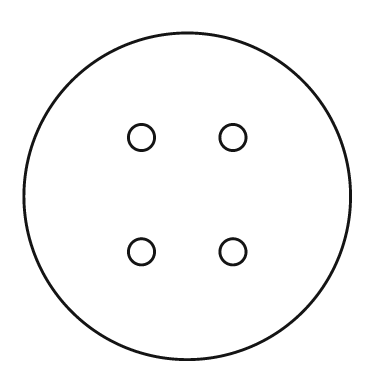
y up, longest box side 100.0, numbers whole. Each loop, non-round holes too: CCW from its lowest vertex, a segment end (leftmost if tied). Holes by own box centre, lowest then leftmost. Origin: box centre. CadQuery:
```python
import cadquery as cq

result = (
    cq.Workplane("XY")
    .moveTo(0.0, 0.0)
    .circle(50.0)
    .moveTo(-14.0, -17.0)
    .circle(4.0)
    .moveTo(14.0, -17.0)
    .circle(4.0)
    .moveTo(-14.0, 18.0)
    .circle(4.0)
    .moveTo(14.0, 18.0)
    .circle(4.0)
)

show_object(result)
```